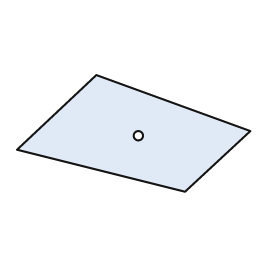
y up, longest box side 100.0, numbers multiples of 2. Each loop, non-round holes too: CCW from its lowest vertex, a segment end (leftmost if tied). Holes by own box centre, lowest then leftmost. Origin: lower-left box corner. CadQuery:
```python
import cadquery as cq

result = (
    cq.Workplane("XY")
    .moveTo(72.0, 0.0)
    .lineTo(100.0, 26.0)
    .lineTo(34.0, 50.0)
    .lineTo(0.0, 18.0)
    .close()
    .moveTo(52.0, 24.0)
    .circle(2.0)
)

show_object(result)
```